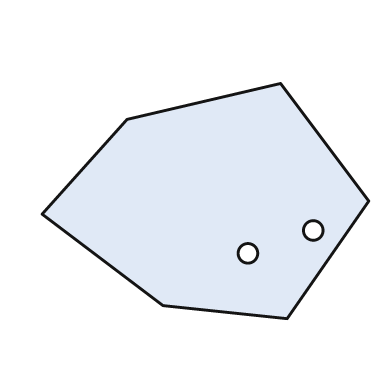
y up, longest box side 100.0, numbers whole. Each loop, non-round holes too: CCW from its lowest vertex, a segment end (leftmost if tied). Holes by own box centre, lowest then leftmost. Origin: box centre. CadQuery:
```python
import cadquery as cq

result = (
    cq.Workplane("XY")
    .moveTo(25.0, -36.0)
    .lineTo(50.0, 0.0)
    .lineTo(23.0, 36.0)
    .lineTo(-24.0, 25.0)
    .lineTo(-50.0, -4.0)
    .lineTo(-13.0, -32.0)
    .close()
    .moveTo(13.0, -16.0)
    .circle(3.0)
    .moveTo(33.0, -9.0)
    .circle(3.0)
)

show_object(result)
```